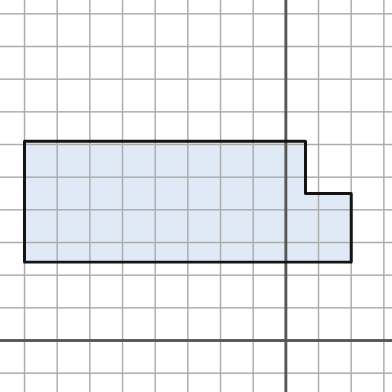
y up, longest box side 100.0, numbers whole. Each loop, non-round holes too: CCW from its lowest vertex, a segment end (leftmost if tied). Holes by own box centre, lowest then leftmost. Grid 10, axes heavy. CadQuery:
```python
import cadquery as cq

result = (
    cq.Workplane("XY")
    .moveTo(-80.0, 24.0)
    .lineTo(20.0, 24.0)
    .lineTo(20.0, 45.0)
    .lineTo(6.0, 45.0)
    .lineTo(6.0, 61.0)
    .lineTo(-80.0, 61.0)
    .close()
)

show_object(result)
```